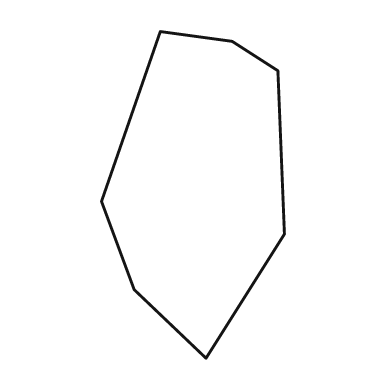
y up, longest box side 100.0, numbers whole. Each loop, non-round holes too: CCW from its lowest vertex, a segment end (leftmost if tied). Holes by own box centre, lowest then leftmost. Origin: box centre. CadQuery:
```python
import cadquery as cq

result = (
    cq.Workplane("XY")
    .moveTo(4.0, -50.0)
    .lineTo(28.0, -12.0)
    .lineTo(26.0, 38.0)
    .lineTo(12.0, 47.0)
    .lineTo(-10.0, 50.0)
    .lineTo(-28.0, -2.0)
    .lineTo(-18.0, -29.0)
    .close()
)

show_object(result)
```